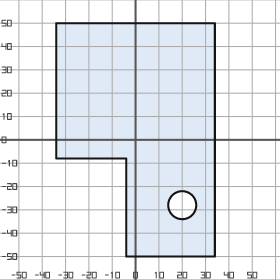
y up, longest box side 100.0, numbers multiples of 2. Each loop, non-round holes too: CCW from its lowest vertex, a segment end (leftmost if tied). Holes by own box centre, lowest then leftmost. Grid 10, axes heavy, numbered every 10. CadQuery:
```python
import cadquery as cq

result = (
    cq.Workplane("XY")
    .moveTo(-4.0, -50.0)
    .lineTo(34.0, -50.0)
    .lineTo(34.0, 50.0)
    .lineTo(-34.0, 50.0)
    .lineTo(-34.0, -8.0)
    .lineTo(-4.0, -8.0)
    .close()
    .moveTo(20.0, -28.0)
    .circle(6.0)
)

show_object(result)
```